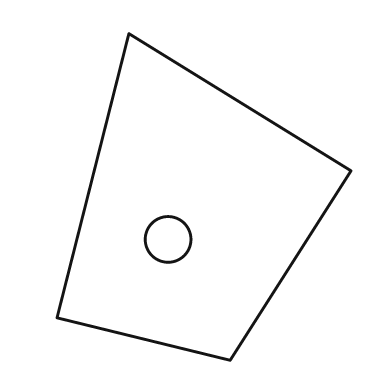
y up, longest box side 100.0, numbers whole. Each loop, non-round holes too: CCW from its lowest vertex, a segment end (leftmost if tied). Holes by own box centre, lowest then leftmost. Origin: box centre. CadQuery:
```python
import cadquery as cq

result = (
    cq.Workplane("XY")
    .moveTo(8.0, -50.0)
    .lineTo(45.0, 8.0)
    .lineTo(-23.0, 50.0)
    .lineTo(-45.0, -37.0)
    .close()
    .moveTo(-11.0, -13.0)
    .circle(7.0)
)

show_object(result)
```